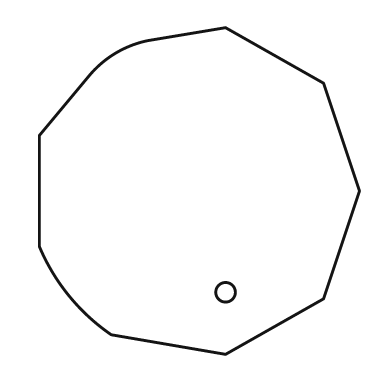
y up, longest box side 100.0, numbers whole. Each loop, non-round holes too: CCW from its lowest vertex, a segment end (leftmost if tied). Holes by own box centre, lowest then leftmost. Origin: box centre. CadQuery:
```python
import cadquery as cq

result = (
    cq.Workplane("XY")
    .moveTo(8.0, -50.0)
    .lineTo(38.0, -33.0)
    .lineTo(49.0, 0.0)
    .lineTo(38.0, 33.0)
    .lineTo(8.0, 50.0)
    .lineTo(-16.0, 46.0)
    .threePointArc((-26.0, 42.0), (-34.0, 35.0))
    .lineTo(-49.0, 17.0)
    .lineTo(-49.0, -17.0)
    .threePointArc((-40.0, -32.0), (-27.0, -44.0))
    .close()
    .moveTo(8.0, -31.0)
    .circle(3.0)
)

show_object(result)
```